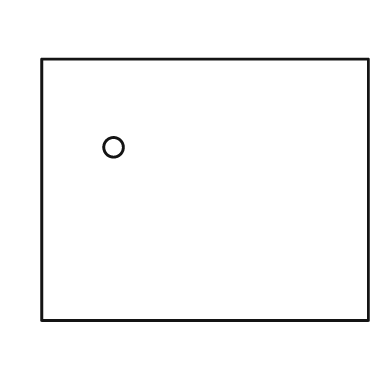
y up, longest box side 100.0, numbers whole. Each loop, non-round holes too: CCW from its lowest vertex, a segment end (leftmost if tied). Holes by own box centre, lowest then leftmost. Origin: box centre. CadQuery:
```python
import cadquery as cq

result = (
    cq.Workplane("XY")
    .moveTo(-50.0, -40.0)
    .lineTo(50.0, -40.0)
    .lineTo(50.0, 40.0)
    .lineTo(-50.0, 40.0)
    .close()
    .moveTo(-28.0, 13.0)
    .circle(3.0)
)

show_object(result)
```